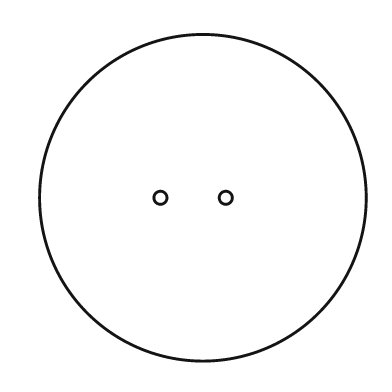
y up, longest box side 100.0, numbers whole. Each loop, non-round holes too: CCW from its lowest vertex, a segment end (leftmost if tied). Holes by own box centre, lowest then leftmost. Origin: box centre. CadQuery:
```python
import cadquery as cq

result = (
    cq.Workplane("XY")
    .moveTo(0.0, 0.0)
    .circle(50.0)
    .moveTo(-13.0, 0.0)
    .circle(2.0)
    .moveTo(7.0, 0.0)
    .circle(2.0)
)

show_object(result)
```